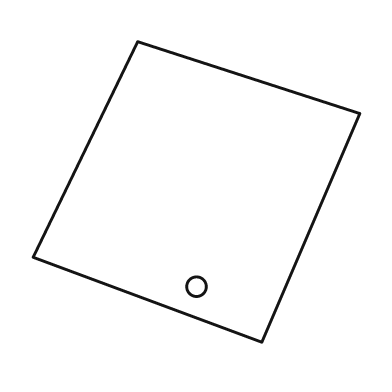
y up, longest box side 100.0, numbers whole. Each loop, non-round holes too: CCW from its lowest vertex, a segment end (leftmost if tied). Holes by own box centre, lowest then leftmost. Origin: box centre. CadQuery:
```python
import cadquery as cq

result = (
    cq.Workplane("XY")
    .moveTo(20.0, -46.0)
    .lineTo(50.0, 24.0)
    .lineTo(-18.0, 46.0)
    .lineTo(-50.0, -20.0)
    .close()
    .moveTo(0.0, -29.0)
    .circle(3.0)
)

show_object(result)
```